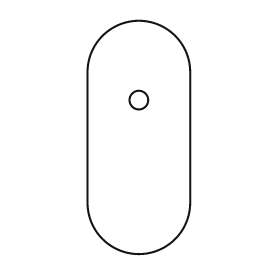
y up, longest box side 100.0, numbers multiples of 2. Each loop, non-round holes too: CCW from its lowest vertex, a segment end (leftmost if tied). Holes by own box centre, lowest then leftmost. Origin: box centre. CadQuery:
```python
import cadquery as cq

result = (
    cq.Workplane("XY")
    .moveTo(-22.0, -28.0)
    .threePointArc((0.0, -50.0), (22.0, -28.0))
    .lineTo(22.0, 28.0)
    .threePointArc((0.0, 50.0), (-22.0, 28.0))
    .close()
    .moveTo(0.0, 16.0)
    .circle(4.0)
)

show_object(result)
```